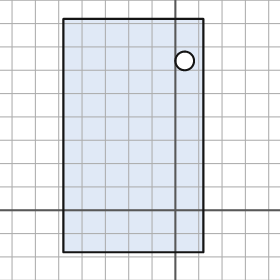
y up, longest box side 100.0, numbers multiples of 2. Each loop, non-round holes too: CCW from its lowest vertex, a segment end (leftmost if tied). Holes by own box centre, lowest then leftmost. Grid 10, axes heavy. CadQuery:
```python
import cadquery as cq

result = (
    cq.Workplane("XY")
    .moveTo(-48.0, -18.0)
    .lineTo(12.0, -18.0)
    .lineTo(12.0, 82.0)
    .lineTo(-48.0, 82.0)
    .close()
    .moveTo(4.0, 64.0)
    .circle(4.0)
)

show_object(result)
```